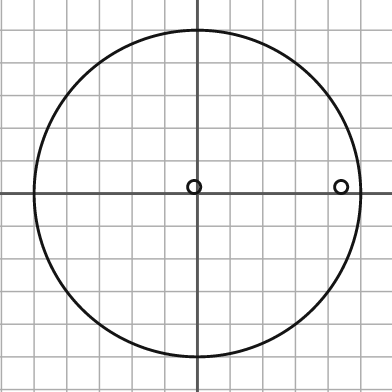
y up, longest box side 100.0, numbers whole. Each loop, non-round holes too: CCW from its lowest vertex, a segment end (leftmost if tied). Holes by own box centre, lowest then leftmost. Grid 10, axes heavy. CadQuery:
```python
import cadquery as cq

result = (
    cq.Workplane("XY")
    .moveTo(0.0, 0.0)
    .circle(50.0)
    .moveTo(-1.0, 2.0)
    .circle(2.0)
    .moveTo(44.0, 2.0)
    .circle(2.0)
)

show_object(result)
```